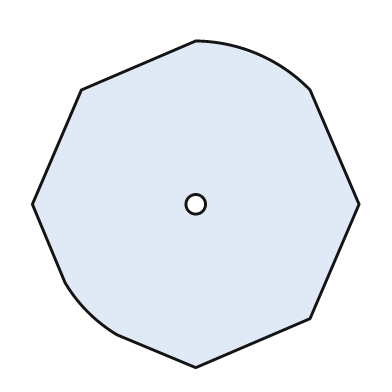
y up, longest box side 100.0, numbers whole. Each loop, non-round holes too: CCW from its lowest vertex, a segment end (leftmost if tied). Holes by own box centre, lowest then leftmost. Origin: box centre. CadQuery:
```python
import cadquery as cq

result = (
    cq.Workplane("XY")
    .moveTo(0.0, -50.0)
    .lineTo(35.0, -35.0)
    .lineTo(50.0, 0.0)
    .lineTo(35.0, 35.0)
    .threePointArc((19.0, 46.0), (0.0, 50.0))
    .lineTo(-35.0, 35.0)
    .lineTo(-50.0, 0.0)
    .lineTo(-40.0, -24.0)
    .threePointArc((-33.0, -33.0), (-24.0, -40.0))
    .close()
    .moveTo(0.0, 0.0)
    .circle(3.0)
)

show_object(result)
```